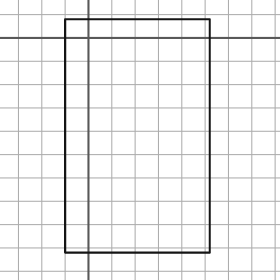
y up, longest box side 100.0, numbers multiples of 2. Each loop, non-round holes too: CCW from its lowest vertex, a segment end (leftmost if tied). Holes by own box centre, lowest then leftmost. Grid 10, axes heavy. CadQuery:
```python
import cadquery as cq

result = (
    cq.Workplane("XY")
    .moveTo(-10.0, -92.0)
    .lineTo(52.0, -92.0)
    .lineTo(52.0, 8.0)
    .lineTo(-10.0, 8.0)
    .close()
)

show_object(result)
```